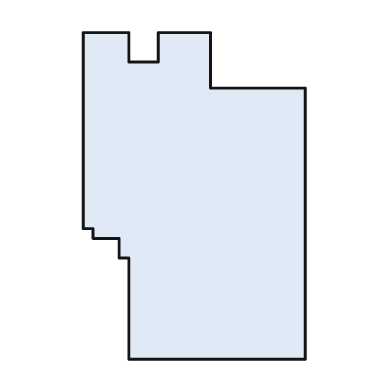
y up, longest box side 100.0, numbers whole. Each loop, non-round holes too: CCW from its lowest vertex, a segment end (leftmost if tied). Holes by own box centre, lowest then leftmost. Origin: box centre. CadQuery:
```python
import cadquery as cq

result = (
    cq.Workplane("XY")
    .moveTo(-20.0, -50.0)
    .lineTo(34.0, -50.0)
    .lineTo(34.0, 33.0)
    .lineTo(5.0, 33.0)
    .lineTo(5.0, 50.0)
    .lineTo(-11.0, 50.0)
    .lineTo(-11.0, 41.0)
    .lineTo(-20.0, 41.0)
    .lineTo(-20.0, 50.0)
    .lineTo(-34.0, 50.0)
    .lineTo(-34.0, -10.0)
    .lineTo(-31.0, -10.0)
    .lineTo(-31.0, -13.0)
    .lineTo(-23.0, -13.0)
    .lineTo(-23.0, -19.0)
    .lineTo(-20.0, -19.0)
    .close()
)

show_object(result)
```